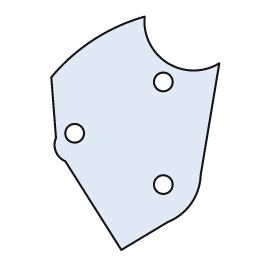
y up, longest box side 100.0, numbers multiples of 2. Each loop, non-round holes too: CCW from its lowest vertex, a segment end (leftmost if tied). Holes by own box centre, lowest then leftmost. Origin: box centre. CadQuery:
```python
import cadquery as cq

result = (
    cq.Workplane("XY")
    .moveTo(-6.0, -50.0)
    .lineTo(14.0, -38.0)
    .threePointArc((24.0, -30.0), (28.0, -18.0))
    .lineTo(36.0, 30.0)
    .threePointArc((14.0, 30.0), (4.0, 50.0))
    .threePointArc((-18.0, 40.0), (-36.0, 24.0))
    .lineTo(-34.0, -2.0)
    .threePointArc((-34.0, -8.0), (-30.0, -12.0))
    .close()
    .moveTo(12.0, -22.0)
    .circle(4.0)
    .moveTo(-26.0, 0.0)
    .circle(4.0)
    .moveTo(12.0, 22.0)
    .circle(4.0)
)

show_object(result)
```